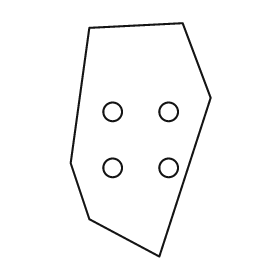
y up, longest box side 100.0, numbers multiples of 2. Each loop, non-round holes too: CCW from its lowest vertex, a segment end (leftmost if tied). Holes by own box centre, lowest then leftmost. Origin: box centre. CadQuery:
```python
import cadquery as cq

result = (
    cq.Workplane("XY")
    .moveTo(8.0, -50.0)
    .lineTo(30.0, 18.0)
    .lineTo(18.0, 50.0)
    .lineTo(-22.0, 48.0)
    .lineTo(-30.0, -10.0)
    .lineTo(-22.0, -34.0)
    .close()
    .moveTo(-12.0, -12.0)
    .circle(4.0)
    .moveTo(12.0, -12.0)
    .circle(4.0)
    .moveTo(-12.0, 12.0)
    .circle(4.0)
    .moveTo(12.0, 12.0)
    .circle(4.0)
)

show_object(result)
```